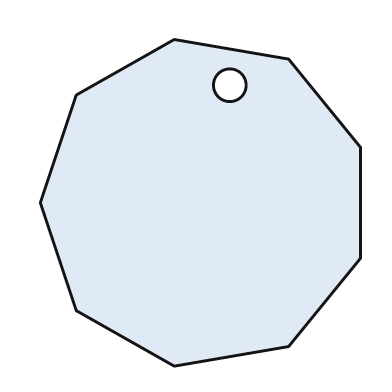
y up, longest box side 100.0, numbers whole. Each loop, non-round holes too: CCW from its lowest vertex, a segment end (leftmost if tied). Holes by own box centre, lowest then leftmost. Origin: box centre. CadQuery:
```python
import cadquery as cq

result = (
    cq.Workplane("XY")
    .moveTo(-8.0, -50.0)
    .lineTo(27.0, -44.0)
    .lineTo(49.0, -17.0)
    .lineTo(49.0, 17.0)
    .lineTo(27.0, 44.0)
    .lineTo(-8.0, 50.0)
    .lineTo(-38.0, 33.0)
    .lineTo(-49.0, 0.0)
    .lineTo(-38.0, -33.0)
    .close()
    .moveTo(9.0, 36.0)
    .circle(5.0)
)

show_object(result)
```